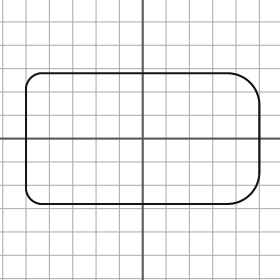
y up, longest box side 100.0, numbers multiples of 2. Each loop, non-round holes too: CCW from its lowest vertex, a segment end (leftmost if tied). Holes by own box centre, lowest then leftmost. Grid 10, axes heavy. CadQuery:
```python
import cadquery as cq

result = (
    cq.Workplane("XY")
    .moveTo(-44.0, -28.0)
    .lineTo(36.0, -28.0)
    .threePointArc((46.0, -24.0), (50.0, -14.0))
    .lineTo(50.0, 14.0)
    .threePointArc((46.0, 24.0), (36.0, 28.0))
    .lineTo(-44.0, 28.0)
    .threePointArc((-48.0, 26.0), (-50.0, 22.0))
    .lineTo(-50.0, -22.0)
    .threePointArc((-48.0, -26.0), (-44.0, -28.0))
    .close()
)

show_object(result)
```